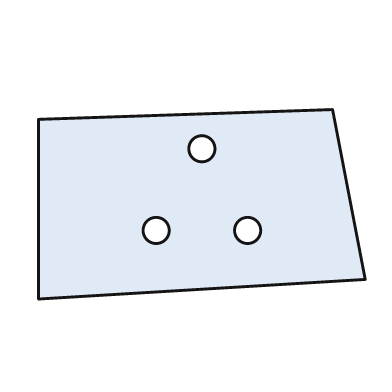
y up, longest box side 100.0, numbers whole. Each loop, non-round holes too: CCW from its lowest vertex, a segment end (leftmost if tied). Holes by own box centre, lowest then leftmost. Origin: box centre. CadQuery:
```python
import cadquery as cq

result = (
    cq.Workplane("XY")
    .moveTo(-50.0, -29.0)
    .lineTo(50.0, -23.0)
    .lineTo(40.0, 29.0)
    .lineTo(-50.0, 26.0)
    .close()
    .moveTo(-14.0, -8.0)
    .circle(4.0)
    .moveTo(14.0, -8.0)
    .circle(4.0)
    .moveTo(0.0, 17.0)
    .circle(4.0)
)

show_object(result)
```